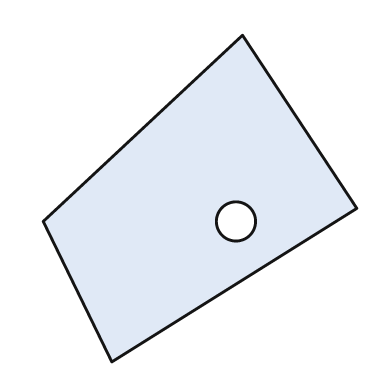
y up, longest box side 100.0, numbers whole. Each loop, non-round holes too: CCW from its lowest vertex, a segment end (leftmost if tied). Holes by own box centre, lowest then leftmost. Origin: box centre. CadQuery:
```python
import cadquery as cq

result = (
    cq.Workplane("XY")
    .moveTo(-27.0, -50.0)
    .lineTo(48.0, -3.0)
    .lineTo(13.0, 50.0)
    .lineTo(-48.0, -7.0)
    .close()
    .moveTo(11.0, -7.0)
    .circle(6.0)
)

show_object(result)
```